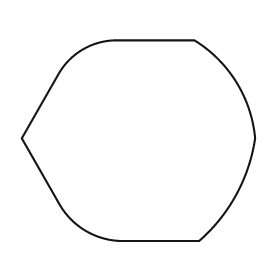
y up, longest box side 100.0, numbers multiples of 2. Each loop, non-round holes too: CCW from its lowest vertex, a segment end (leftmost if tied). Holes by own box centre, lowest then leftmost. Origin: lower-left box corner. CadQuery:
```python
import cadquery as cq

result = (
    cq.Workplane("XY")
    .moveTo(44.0, 0.0)
    .lineTo(76.0, 0.0)
    .threePointArc((92.0, 20.0), (100.0, 44.0))
    .threePointArc((92.0, 68.0), (74.0, 86.0))
    .lineTo(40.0, 86.0)
    .threePointArc((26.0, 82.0), (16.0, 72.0))
    .lineTo(0.0, 44.0)
    .lineTo(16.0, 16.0)
    .threePointArc((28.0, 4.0), (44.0, 0.0))
    .close()
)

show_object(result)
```